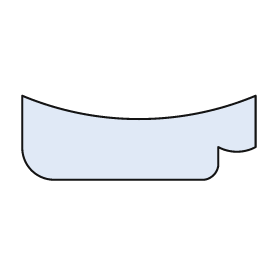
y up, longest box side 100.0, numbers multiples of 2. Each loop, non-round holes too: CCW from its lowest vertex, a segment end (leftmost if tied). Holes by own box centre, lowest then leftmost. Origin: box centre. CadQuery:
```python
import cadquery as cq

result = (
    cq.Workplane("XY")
    .moveTo(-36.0, -18.0)
    .lineTo(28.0, -18.0)
    .threePointArc((32.0, -16.0), (34.0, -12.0))
    .lineTo(34.0, -4.0)
    .threePointArc((42.0, -6.0), (50.0, -4.0))
    .lineTo(50.0, 18.0)
    .threePointArc((0.0, 8.0), (-50.0, 18.0))
    .lineTo(-50.0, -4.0)
    .threePointArc((-46.0, -14.0), (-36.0, -18.0))
    .close()
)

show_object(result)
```